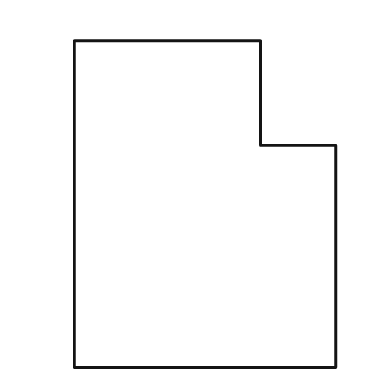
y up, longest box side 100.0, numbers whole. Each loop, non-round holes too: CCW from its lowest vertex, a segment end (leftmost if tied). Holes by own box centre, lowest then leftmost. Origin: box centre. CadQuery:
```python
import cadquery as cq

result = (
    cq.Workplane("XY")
    .moveTo(-40.0, -50.0)
    .lineTo(40.0, -50.0)
    .lineTo(40.0, 18.0)
    .lineTo(17.0, 18.0)
    .lineTo(17.0, 50.0)
    .lineTo(-40.0, 50.0)
    .close()
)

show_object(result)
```